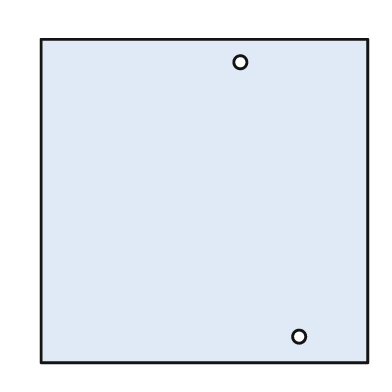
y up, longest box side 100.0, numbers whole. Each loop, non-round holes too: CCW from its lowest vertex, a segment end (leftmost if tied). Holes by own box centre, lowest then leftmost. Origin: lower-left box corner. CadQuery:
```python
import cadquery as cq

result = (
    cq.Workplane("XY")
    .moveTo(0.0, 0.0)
    .lineTo(100.0, 0.0)
    .lineTo(100.0, 99.0)
    .lineTo(0.0, 99.0)
    .close()
    .moveTo(79.0, 8.0)
    .circle(2.0)
    .moveTo(61.0, 92.0)
    .circle(2.0)
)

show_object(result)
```